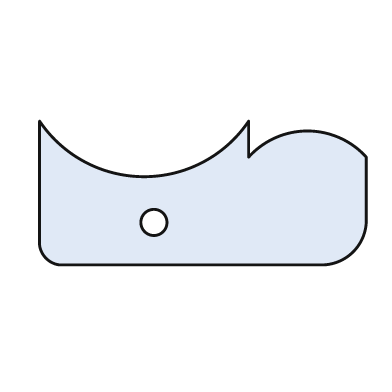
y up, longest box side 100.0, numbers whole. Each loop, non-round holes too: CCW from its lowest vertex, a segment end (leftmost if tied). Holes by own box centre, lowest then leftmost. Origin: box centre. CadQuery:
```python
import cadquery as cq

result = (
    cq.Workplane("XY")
    .moveTo(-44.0, -22.0)
    .lineTo(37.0, -22.0)
    .threePointArc((46.0, -18.0), (50.0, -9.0))
    .lineTo(50.0, 11.0)
    .threePointArc((32.0, 19.0), (14.0, 11.0))
    .lineTo(14.0, 22.0)
    .threePointArc((-18.0, 5.0), (-50.0, 22.0))
    .lineTo(-50.0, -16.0)
    .threePointArc((-48.0, -20.0), (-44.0, -22.0))
    .close()
    .moveTo(-15.0, -9.0)
    .circle(4.0)
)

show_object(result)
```